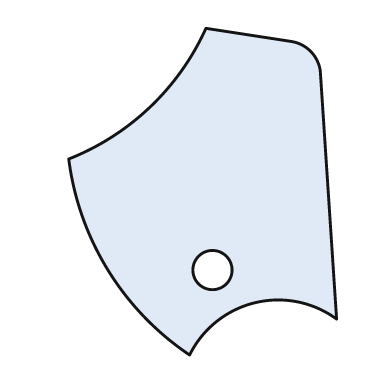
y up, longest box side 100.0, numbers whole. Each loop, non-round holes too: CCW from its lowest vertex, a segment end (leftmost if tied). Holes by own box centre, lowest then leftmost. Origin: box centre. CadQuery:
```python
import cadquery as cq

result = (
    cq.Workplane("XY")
    .moveTo(-4.0, -50.0)
    .threePointArc((16.0, -34.0), (41.0, -39.0))
    .lineTo(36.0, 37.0)
    .threePointArc((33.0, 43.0), (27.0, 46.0))
    .lineTo(1.0, 50.0)
    .threePointArc((-16.0, 26.0), (-41.0, 10.0))
    .threePointArc((-29.0, -24.0), (-4.0, -50.0))
    .close()
    .moveTo(3.0, -24.0)
    .circle(6.0)
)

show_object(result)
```